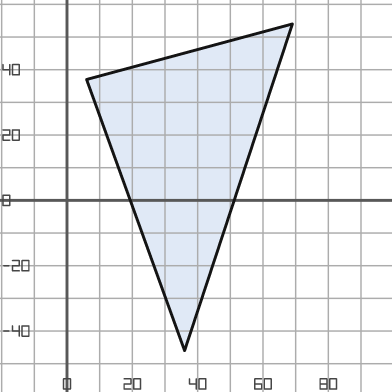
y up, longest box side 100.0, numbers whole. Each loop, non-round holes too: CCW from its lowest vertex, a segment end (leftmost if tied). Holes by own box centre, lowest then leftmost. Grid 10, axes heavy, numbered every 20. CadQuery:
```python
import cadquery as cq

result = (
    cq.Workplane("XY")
    .moveTo(36.0, -46.0)
    .lineTo(69.0, 54.0)
    .lineTo(6.0, 37.0)
    .close()
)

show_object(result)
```